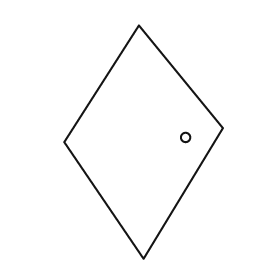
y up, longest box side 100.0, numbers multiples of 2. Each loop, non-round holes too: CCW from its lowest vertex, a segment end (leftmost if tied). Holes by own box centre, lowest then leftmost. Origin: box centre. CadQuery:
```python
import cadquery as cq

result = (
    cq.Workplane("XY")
    .moveTo(0.0, -50.0)
    .lineTo(34.0, 6.0)
    .lineTo(-2.0, 50.0)
    .lineTo(-34.0, 0.0)
    .close()
    .moveTo(18.0, 2.0)
    .circle(2.0)
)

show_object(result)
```